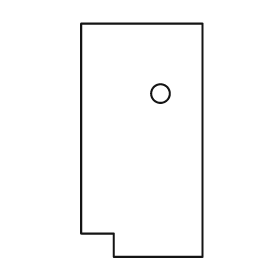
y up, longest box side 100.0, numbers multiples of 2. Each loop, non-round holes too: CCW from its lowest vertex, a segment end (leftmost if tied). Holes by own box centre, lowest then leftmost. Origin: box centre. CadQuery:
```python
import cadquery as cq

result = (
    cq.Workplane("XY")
    .moveTo(-12.0, -50.0)
    .lineTo(26.0, -50.0)
    .lineTo(26.0, 50.0)
    .lineTo(-26.0, 50.0)
    .lineTo(-26.0, -40.0)
    .lineTo(-12.0, -40.0)
    .close()
    .moveTo(8.0, 20.0)
    .circle(4.0)
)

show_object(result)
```